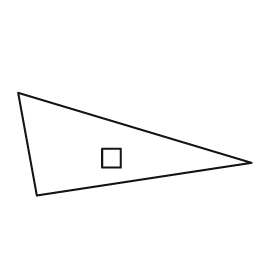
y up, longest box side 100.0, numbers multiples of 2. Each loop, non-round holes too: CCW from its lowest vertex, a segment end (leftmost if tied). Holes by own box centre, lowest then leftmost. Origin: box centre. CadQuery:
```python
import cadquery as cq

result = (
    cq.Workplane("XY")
    .moveTo(-42.0, -22.0)
    .lineTo(50.0, -8.0)
    .lineTo(-50.0, 22.0)
    .close()
    .moveTo(-14.0, -10.0)
    .lineTo(-6.0, -10.0)
    .lineTo(-6.0, -2.0)
    .lineTo(-14.0, -2.0)
    .close()
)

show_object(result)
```